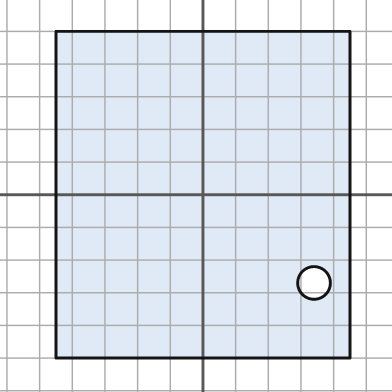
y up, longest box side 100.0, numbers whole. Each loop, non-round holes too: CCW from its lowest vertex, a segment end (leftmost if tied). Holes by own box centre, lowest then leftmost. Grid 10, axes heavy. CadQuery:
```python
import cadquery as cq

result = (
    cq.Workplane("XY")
    .moveTo(-45.0, -50.0)
    .lineTo(45.0, -50.0)
    .lineTo(45.0, 50.0)
    .lineTo(-45.0, 50.0)
    .close()
    .moveTo(34.0, -27.0)
    .circle(5.0)
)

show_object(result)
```